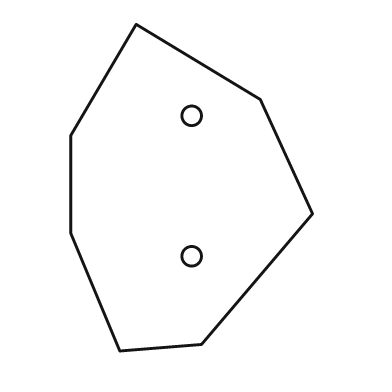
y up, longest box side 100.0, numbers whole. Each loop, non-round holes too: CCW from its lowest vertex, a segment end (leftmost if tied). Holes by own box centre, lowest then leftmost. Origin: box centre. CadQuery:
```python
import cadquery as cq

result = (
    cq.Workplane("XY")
    .moveTo(-22.0, -50.0)
    .lineTo(3.0, -48.0)
    .lineTo(37.0, -8.0)
    .lineTo(21.0, 27.0)
    .lineTo(-17.0, 50.0)
    .lineTo(-37.0, 16.0)
    .lineTo(-37.0, -14.0)
    .close()
    .moveTo(0.0, -21.0)
    .circle(3.0)
    .moveTo(0.0, 22.0)
    .circle(3.0)
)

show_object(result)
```